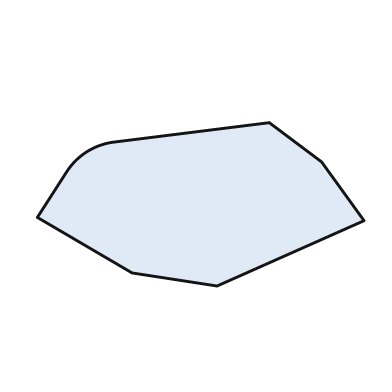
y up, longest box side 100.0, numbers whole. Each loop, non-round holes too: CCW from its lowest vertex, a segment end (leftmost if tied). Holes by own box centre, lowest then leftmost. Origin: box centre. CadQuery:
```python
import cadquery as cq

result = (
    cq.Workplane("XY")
    .moveTo(5.0, -25.0)
    .lineTo(50.0, -5.0)
    .lineTo(37.0, 13.0)
    .lineTo(21.0, 25.0)
    .lineTo(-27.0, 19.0)
    .threePointArc((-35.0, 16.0), (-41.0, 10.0))
    .lineTo(-50.0, -4.0)
    .lineTo(-21.0, -21.0)
    .close()
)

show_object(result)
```